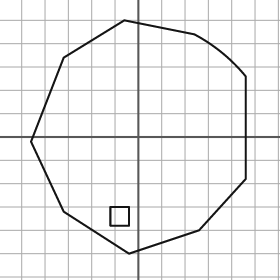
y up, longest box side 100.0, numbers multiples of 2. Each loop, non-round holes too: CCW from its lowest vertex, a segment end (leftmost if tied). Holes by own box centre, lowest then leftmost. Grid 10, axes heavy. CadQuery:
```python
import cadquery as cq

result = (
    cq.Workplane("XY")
    .moveTo(-4.0, -50.0)
    .lineTo(26.0, -40.0)
    .lineTo(46.0, -18.0)
    .lineTo(46.0, 26.0)
    .threePointArc((36.0, 36.0), (24.0, 44.0))
    .lineTo(-6.0, 50.0)
    .lineTo(-32.0, 34.0)
    .lineTo(-46.0, -2.0)
    .lineTo(-32.0, -32.0)
    .close()
    .moveTo(-12.0, -38.0)
    .lineTo(-4.0, -38.0)
    .lineTo(-4.0, -30.0)
    .lineTo(-12.0, -30.0)
    .close()
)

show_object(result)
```